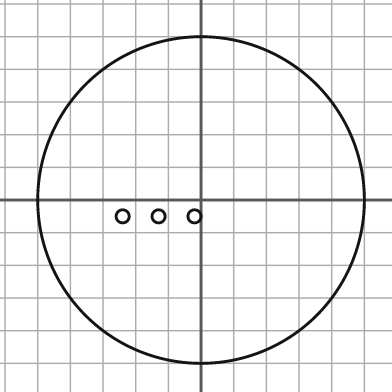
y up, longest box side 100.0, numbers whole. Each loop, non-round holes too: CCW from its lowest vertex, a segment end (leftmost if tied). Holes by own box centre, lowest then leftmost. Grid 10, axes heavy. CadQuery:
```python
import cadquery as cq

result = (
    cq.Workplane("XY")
    .moveTo(0.0, 0.0)
    .circle(50.0)
    .moveTo(-24.0, -5.0)
    .circle(2.0)
    .moveTo(-13.0, -5.0)
    .circle(2.0)
    .moveTo(-2.0, -5.0)
    .circle(2.0)
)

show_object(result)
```